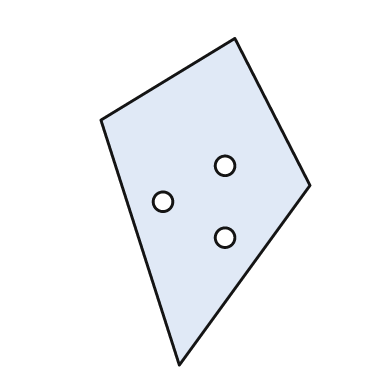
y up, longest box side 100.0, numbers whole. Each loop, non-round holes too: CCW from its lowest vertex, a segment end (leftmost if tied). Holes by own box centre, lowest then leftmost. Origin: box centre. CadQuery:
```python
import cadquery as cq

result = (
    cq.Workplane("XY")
    .moveTo(-8.0, -50.0)
    .lineTo(32.0, 5.0)
    .lineTo(9.0, 50.0)
    .lineTo(-32.0, 25.0)
    .close()
    .moveTo(6.0, -11.0)
    .circle(3.0)
    .moveTo(-13.0, 0.0)
    .circle(3.0)
    .moveTo(6.0, 11.0)
    .circle(3.0)
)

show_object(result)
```